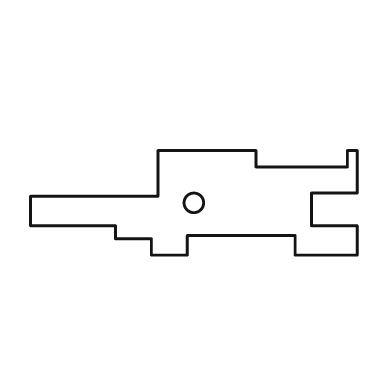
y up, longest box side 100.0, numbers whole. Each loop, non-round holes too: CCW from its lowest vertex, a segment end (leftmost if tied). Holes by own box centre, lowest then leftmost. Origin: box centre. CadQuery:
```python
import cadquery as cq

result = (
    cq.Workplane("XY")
    .moveTo(-13.0, -16.0)
    .lineTo(-2.0, -16.0)
    .lineTo(-2.0, -10.0)
    .lineTo(31.0, -10.0)
    .lineTo(31.0, -16.0)
    .lineTo(50.0, -16.0)
    .lineTo(50.0, -7.0)
    .lineTo(36.0, -7.0)
    .lineTo(36.0, 3.0)
    .lineTo(50.0, 3.0)
    .lineTo(50.0, 16.0)
    .lineTo(47.0, 16.0)
    .lineTo(47.0, 11.0)
    .lineTo(19.0, 11.0)
    .lineTo(19.0, 16.0)
    .lineTo(-11.0, 16.0)
    .lineTo(-11.0, 2.0)
    .lineTo(-50.0, 2.0)
    .lineTo(-50.0, -7.0)
    .lineTo(-24.0, -7.0)
    .lineTo(-24.0, -11.0)
    .lineTo(-13.0, -11.0)
    .close()
    .moveTo(0.0, 0.0)
    .circle(3.0)
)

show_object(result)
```